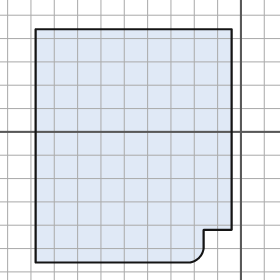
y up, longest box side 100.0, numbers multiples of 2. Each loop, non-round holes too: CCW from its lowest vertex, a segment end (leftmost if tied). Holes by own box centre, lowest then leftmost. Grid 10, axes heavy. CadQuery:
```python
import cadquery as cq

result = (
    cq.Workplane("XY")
    .moveTo(-88.0, -56.0)
    .lineTo(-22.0, -56.0)
    .threePointArc((-18.0, -54.0), (-16.0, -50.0))
    .lineTo(-16.0, -42.0)
    .lineTo(-4.0, -42.0)
    .lineTo(-4.0, 44.0)
    .lineTo(-88.0, 44.0)
    .close()
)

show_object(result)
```